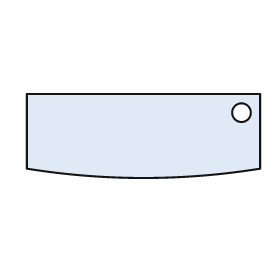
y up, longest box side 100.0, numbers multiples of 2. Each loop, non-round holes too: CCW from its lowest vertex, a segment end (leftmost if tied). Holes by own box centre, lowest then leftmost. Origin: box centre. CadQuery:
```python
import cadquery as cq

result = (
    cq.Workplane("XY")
    .moveTo(-50.0, -14.0)
    .threePointArc((0.0, -18.0), (50.0, -14.0))
    .lineTo(50.0, 18.0)
    .lineTo(-50.0, 18.0)
    .close()
    .moveTo(42.0, 10.0)
    .circle(4.0)
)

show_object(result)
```